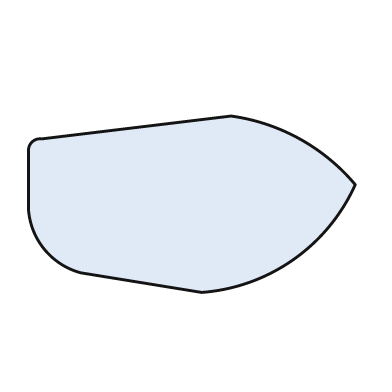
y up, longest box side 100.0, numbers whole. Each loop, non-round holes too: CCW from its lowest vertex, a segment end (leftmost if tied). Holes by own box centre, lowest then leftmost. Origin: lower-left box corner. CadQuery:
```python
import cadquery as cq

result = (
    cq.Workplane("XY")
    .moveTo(53.0, 0.0)
    .threePointArc((81.0, 10.0), (100.0, 33.0))
    .threePointArc((83.0, 47.0), (62.0, 54.0))
    .lineTo(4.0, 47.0)
    .threePointArc((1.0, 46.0), (0.0, 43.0))
    .lineTo(0.0, 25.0)
    .threePointArc((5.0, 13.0), (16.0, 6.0))
    .close()
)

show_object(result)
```